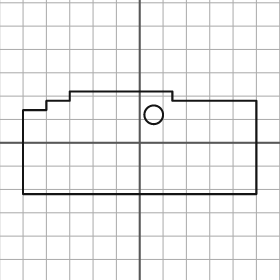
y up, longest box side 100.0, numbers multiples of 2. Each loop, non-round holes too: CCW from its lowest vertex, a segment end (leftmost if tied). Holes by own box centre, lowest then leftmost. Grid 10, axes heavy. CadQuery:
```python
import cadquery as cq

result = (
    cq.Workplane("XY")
    .moveTo(-50.0, -22.0)
    .lineTo(50.0, -22.0)
    .lineTo(50.0, 18.0)
    .lineTo(14.0, 18.0)
    .lineTo(14.0, 22.0)
    .lineTo(-30.0, 22.0)
    .lineTo(-30.0, 18.0)
    .lineTo(-40.0, 18.0)
    .lineTo(-40.0, 14.0)
    .lineTo(-50.0, 14.0)
    .close()
    .moveTo(6.0, 12.0)
    .circle(4.0)
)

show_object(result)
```